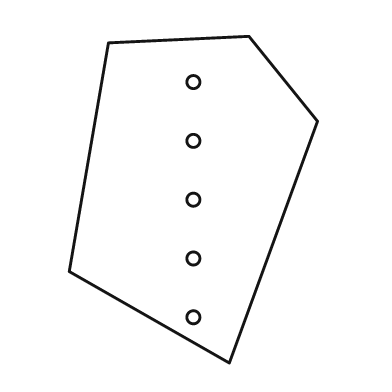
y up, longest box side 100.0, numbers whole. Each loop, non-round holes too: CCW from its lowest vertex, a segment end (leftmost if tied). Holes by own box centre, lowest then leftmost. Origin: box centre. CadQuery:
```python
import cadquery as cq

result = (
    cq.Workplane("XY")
    .moveTo(11.0, -50.0)
    .lineTo(38.0, 24.0)
    .lineTo(17.0, 50.0)
    .lineTo(-26.0, 48.0)
    .lineTo(-38.0, -22.0)
    .close()
    .moveTo(0.0, -36.0)
    .circle(2.0)
    .moveTo(0.0, -18.0)
    .circle(2.0)
    .moveTo(0.0, 0.0)
    .circle(2.0)
    .moveTo(0.0, 18.0)
    .circle(2.0)
    .moveTo(0.0, 36.0)
    .circle(2.0)
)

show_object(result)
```